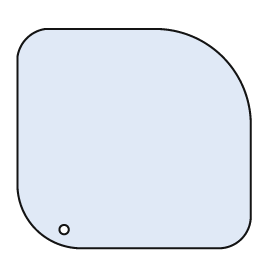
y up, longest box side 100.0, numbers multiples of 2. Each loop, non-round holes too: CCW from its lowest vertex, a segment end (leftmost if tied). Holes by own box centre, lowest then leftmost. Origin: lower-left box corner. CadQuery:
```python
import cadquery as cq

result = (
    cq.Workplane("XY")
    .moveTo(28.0, 0.0)
    .lineTo(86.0, 0.0)
    .threePointArc((96.0, 4.0), (100.0, 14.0))
    .lineTo(100.0, 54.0)
    .threePointArc((88.0, 82.0), (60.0, 94.0))
    .lineTo(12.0, 94.0)
    .threePointArc((4.0, 90.0), (0.0, 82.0))
    .lineTo(0.0, 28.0)
    .threePointArc((8.0, 8.0), (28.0, 0.0))
    .close()
    .moveTo(20.0, 8.0)
    .circle(2.0)
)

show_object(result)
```